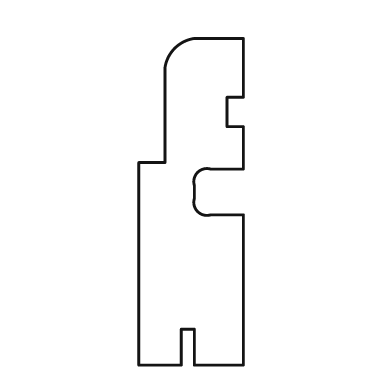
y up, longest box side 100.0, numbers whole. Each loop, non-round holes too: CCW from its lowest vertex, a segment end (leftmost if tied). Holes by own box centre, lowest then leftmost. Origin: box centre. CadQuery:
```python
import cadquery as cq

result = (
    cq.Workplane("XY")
    .moveTo(-16.0, -50.0)
    .lineTo(-3.0, -50.0)
    .lineTo(-3.0, -39.0)
    .lineTo(1.0, -39.0)
    .lineTo(1.0, -50.0)
    .lineTo(16.0, -50.0)
    .lineTo(16.0, -4.0)
    .lineTo(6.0, -4.0)
    .threePointArc((2.0, -3.0), (1.0, 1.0))
    .lineTo(1.0, 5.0)
    .threePointArc((2.0, 9.0), (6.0, 10.0))
    .lineTo(16.0, 10.0)
    .lineTo(16.0, 23.0)
    .lineTo(11.0, 23.0)
    .lineTo(11.0, 32.0)
    .lineTo(16.0, 32.0)
    .lineTo(16.0, 50.0)
    .lineTo(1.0, 50.0)
    .threePointArc((-5.0, 47.0), (-8.0, 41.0))
    .lineTo(-8.0, 12.0)
    .lineTo(-16.0, 12.0)
    .close()
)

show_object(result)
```